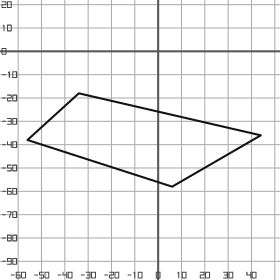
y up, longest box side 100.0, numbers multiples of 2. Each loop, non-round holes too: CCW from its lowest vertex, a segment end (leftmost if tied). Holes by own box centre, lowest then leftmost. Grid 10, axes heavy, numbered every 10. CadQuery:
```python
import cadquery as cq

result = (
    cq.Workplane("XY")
    .moveTo(6.0, -58.0)
    .lineTo(44.0, -36.0)
    .lineTo(-34.0, -18.0)
    .lineTo(-56.0, -38.0)
    .close()
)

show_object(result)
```